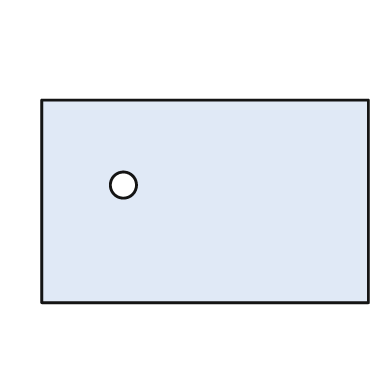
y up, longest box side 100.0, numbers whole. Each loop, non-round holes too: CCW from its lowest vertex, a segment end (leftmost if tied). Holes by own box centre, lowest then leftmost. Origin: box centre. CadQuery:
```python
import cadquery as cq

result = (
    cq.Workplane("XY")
    .moveTo(-50.0, -31.0)
    .lineTo(50.0, -31.0)
    .lineTo(50.0, 31.0)
    .lineTo(-50.0, 31.0)
    .close()
    .moveTo(-25.0, 5.0)
    .circle(4.0)
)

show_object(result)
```